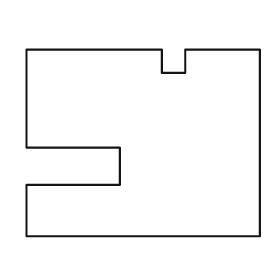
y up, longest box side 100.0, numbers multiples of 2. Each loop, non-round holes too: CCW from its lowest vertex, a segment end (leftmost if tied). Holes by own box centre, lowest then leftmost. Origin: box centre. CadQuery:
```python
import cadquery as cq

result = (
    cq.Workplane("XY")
    .moveTo(-50.0, -40.0)
    .lineTo(50.0, -40.0)
    .lineTo(50.0, 40.0)
    .lineTo(18.0, 40.0)
    .lineTo(18.0, 30.0)
    .lineTo(8.0, 30.0)
    .lineTo(8.0, 40.0)
    .lineTo(-50.0, 40.0)
    .lineTo(-50.0, -2.0)
    .lineTo(-10.0, -2.0)
    .lineTo(-10.0, -18.0)
    .lineTo(-50.0, -18.0)
    .close()
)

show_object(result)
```